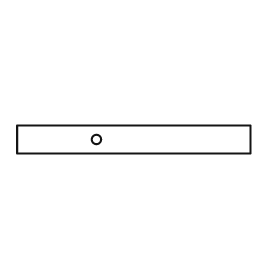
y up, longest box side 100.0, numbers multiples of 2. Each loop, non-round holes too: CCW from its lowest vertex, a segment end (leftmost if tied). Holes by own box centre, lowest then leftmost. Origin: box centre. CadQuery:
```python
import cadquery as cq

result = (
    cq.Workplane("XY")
    .moveTo(-50.0, -6.0)
    .lineTo(50.0, -6.0)
    .lineTo(50.0, 6.0)
    .lineTo(-50.0, 6.0)
    .close()
    .moveTo(-16.0, 0.0)
    .circle(2.0)
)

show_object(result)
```